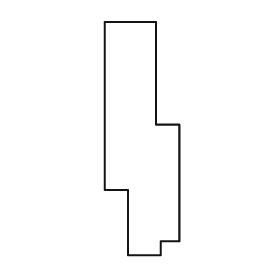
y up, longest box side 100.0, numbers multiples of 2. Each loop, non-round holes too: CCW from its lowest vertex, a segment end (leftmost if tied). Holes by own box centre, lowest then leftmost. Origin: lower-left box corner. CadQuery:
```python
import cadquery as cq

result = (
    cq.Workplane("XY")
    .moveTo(10.0, 0.0)
    .lineTo(24.0, 0.0)
    .lineTo(24.0, 6.0)
    .lineTo(32.0, 6.0)
    .lineTo(32.0, 56.0)
    .lineTo(22.0, 56.0)
    .lineTo(22.0, 100.0)
    .lineTo(0.0, 100.0)
    .lineTo(0.0, 28.0)
    .lineTo(10.0, 28.0)
    .close()
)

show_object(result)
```